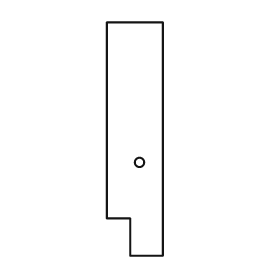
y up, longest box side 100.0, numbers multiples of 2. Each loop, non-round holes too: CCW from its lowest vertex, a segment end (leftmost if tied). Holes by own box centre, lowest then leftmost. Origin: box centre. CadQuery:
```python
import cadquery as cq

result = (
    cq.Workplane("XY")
    .moveTo(-2.0, -50.0)
    .lineTo(12.0, -50.0)
    .lineTo(12.0, 50.0)
    .lineTo(-12.0, 50.0)
    .lineTo(-12.0, -34.0)
    .lineTo(-2.0, -34.0)
    .close()
    .moveTo(2.0, -10.0)
    .circle(2.0)
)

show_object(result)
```